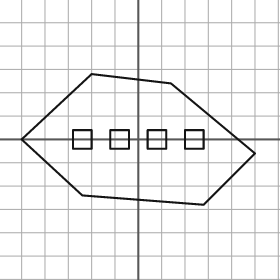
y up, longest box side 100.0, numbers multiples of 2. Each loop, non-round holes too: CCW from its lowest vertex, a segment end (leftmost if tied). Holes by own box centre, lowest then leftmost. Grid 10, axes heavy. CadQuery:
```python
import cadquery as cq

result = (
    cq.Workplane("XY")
    .moveTo(28.0, -28.0)
    .lineTo(50.0, -6.0)
    .lineTo(14.0, 24.0)
    .lineTo(-20.0, 28.0)
    .lineTo(-50.0, 0.0)
    .lineTo(-24.0, -24.0)
    .close()
    .moveTo(-28.0, -4.0)
    .lineTo(-20.0, -4.0)
    .lineTo(-20.0, 4.0)
    .lineTo(-28.0, 4.0)
    .close()
    .moveTo(-12.0, -4.0)
    .lineTo(-4.0, -4.0)
    .lineTo(-4.0, 4.0)
    .lineTo(-12.0, 4.0)
    .close()
    .moveTo(4.0, -4.0)
    .lineTo(12.0, -4.0)
    .lineTo(12.0, 4.0)
    .lineTo(4.0, 4.0)
    .close()
    .moveTo(20.0, -4.0)
    .lineTo(28.0, -4.0)
    .lineTo(28.0, 4.0)
    .lineTo(20.0, 4.0)
    .close()
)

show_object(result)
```